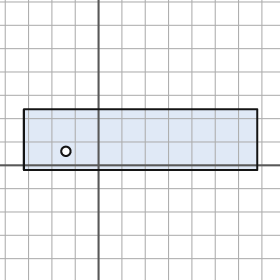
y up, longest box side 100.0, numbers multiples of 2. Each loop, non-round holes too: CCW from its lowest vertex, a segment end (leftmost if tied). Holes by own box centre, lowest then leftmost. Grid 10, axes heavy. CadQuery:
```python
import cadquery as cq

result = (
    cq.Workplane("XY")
    .moveTo(-32.0, -2.0)
    .lineTo(68.0, -2.0)
    .lineTo(68.0, 24.0)
    .lineTo(-32.0, 24.0)
    .close()
    .moveTo(-14.0, 6.0)
    .circle(2.0)
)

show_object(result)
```